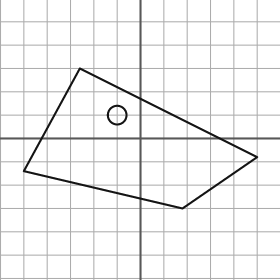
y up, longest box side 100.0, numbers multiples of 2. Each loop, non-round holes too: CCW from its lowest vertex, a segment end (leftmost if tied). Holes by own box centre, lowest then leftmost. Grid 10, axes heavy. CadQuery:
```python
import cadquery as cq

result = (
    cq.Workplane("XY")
    .moveTo(18.0, -30.0)
    .lineTo(50.0, -8.0)
    .lineTo(-26.0, 30.0)
    .lineTo(-50.0, -14.0)
    .close()
    .moveTo(-10.0, 10.0)
    .circle(4.0)
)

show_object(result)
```